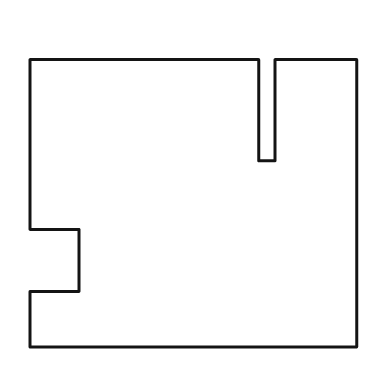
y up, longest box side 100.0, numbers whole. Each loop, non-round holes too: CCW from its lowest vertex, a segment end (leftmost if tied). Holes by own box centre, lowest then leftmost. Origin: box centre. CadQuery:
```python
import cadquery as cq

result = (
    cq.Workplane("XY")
    .moveTo(-50.0, -44.0)
    .lineTo(50.0, -44.0)
    .lineTo(50.0, 44.0)
    .lineTo(25.0, 44.0)
    .lineTo(25.0, 13.0)
    .lineTo(20.0, 13.0)
    .lineTo(20.0, 44.0)
    .lineTo(-50.0, 44.0)
    .lineTo(-50.0, -8.0)
    .lineTo(-35.0, -8.0)
    .lineTo(-35.0, -27.0)
    .lineTo(-50.0, -27.0)
    .close()
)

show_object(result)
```